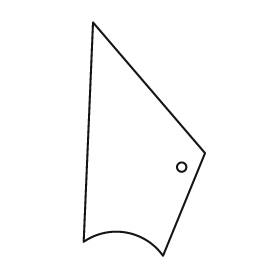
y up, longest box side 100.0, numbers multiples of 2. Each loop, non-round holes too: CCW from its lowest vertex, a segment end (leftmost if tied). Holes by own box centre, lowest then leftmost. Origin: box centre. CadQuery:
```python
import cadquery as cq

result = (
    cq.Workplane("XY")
    .moveTo(8.0, -50.0)
    .lineTo(26.0, -6.0)
    .lineTo(-22.0, 50.0)
    .lineTo(-26.0, -44.0)
    .threePointArc((-8.0, -40.0), (8.0, -50.0))
    .close()
    .moveTo(16.0, -12.0)
    .circle(2.0)
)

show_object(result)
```